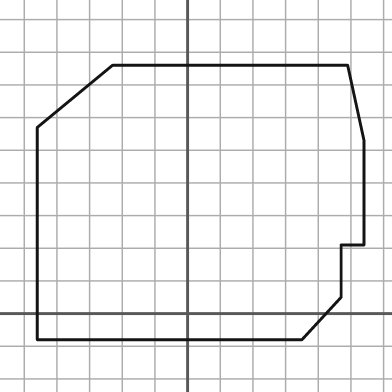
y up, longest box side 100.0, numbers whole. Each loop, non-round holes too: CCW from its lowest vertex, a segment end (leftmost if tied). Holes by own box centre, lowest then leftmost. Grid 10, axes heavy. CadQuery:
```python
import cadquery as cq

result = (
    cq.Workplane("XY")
    .moveTo(-46.0, -8.0)
    .lineTo(35.0, -8.0)
    .lineTo(47.0, 5.0)
    .lineTo(47.0, 21.0)
    .lineTo(54.0, 21.0)
    .lineTo(54.0, 53.0)
    .lineTo(49.0, 76.0)
    .lineTo(-23.0, 76.0)
    .lineTo(-46.0, 57.0)
    .close()
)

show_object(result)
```